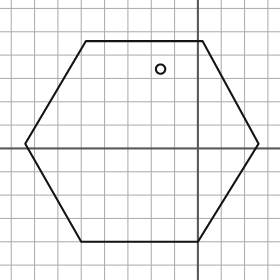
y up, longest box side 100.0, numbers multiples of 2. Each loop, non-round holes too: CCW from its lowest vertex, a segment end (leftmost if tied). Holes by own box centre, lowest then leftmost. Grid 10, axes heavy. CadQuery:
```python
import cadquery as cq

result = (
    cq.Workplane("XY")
    .moveTo(-50.0, -40.0)
    .lineTo(0.0, -40.0)
    .lineTo(26.0, 2.0)
    .lineTo(2.0, 46.0)
    .lineTo(-48.0, 46.0)
    .lineTo(-74.0, 2.0)
    .close()
    .moveTo(-16.0, 34.0)
    .circle(2.0)
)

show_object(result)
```